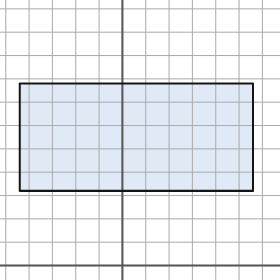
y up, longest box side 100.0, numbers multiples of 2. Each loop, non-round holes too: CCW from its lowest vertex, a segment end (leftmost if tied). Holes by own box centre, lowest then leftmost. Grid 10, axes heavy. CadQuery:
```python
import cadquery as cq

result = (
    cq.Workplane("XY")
    .moveTo(-44.0, 32.0)
    .lineTo(56.0, 32.0)
    .lineTo(56.0, 78.0)
    .lineTo(-44.0, 78.0)
    .close()
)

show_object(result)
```